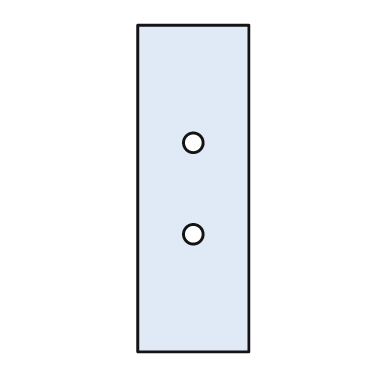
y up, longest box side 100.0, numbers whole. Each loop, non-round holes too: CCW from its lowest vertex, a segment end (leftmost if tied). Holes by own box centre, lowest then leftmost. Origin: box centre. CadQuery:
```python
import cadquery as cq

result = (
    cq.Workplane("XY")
    .moveTo(-17.0, -50.0)
    .lineTo(17.0, -50.0)
    .lineTo(17.0, 50.0)
    .lineTo(-17.0, 50.0)
    .close()
    .moveTo(0.0, -14.0)
    .circle(3.0)
    .moveTo(0.0, 14.0)
    .circle(3.0)
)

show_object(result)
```